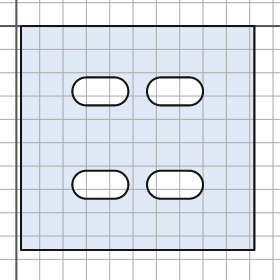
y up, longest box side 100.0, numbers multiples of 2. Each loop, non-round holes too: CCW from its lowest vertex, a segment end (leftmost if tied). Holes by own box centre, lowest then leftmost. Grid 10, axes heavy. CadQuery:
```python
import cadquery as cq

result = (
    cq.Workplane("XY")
    .moveTo(2.0, -96.0)
    .lineTo(102.0, -96.0)
    .lineTo(102.0, 0.0)
    .lineTo(2.0, 0.0)
    .close()
    .moveTo(30.0, -74.0)
    .lineTo(42.0, -74.0)
    .threePointArc((48.0, -68.0), (42.0, -62.0))
    .lineTo(30.0, -62.0)
    .threePointArc((24.0, -68.0), (30.0, -74.0))
    .close()
    .moveTo(62.0, -74.0)
    .lineTo(74.0, -74.0)
    .threePointArc((80.0, -68.0), (74.0, -62.0))
    .lineTo(62.0, -62.0)
    .threePointArc((56.0, -68.0), (62.0, -74.0))
    .close()
    .moveTo(30.0, -34.0)
    .lineTo(42.0, -34.0)
    .threePointArc((48.0, -28.0), (42.0, -22.0))
    .lineTo(30.0, -22.0)
    .threePointArc((24.0, -28.0), (30.0, -34.0))
    .close()
    .moveTo(62.0, -34.0)
    .lineTo(74.0, -34.0)
    .threePointArc((80.0, -28.0), (74.0, -22.0))
    .lineTo(62.0, -22.0)
    .threePointArc((56.0, -28.0), (62.0, -34.0))
    .close()
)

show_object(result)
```